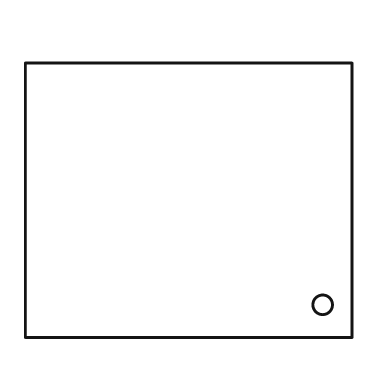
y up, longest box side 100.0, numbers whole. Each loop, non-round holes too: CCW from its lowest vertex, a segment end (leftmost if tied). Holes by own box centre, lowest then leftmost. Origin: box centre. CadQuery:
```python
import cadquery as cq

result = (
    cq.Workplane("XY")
    .moveTo(-50.0, -42.0)
    .lineTo(50.0, -42.0)
    .lineTo(50.0, 42.0)
    .lineTo(-50.0, 42.0)
    .close()
    .moveTo(41.0, -32.0)
    .circle(3.0)
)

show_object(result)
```